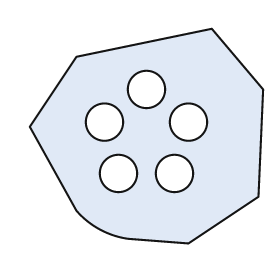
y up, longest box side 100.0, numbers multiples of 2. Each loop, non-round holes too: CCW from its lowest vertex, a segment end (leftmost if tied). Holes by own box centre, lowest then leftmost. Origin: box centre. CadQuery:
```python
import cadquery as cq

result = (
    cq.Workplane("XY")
    .moveTo(18.0, -46.0)
    .lineTo(48.0, -26.0)
    .lineTo(50.0, 20.0)
    .lineTo(28.0, 46.0)
    .lineTo(-30.0, 34.0)
    .lineTo(-50.0, 4.0)
    .lineTo(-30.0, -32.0)
    .threePointArc((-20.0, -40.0), (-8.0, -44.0))
    .close()
    .moveTo(-12.0, -16.0)
    .circle(8.0)
    .moveTo(12.0, -16.0)
    .circle(8.0)
    .moveTo(-18.0, 6.0)
    .circle(8.0)
    .moveTo(18.0, 6.0)
    .circle(8.0)
    .moveTo(0.0, 20.0)
    .circle(8.0)
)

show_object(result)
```